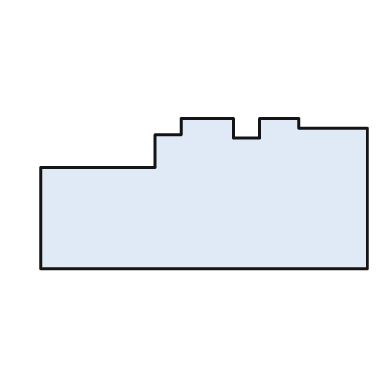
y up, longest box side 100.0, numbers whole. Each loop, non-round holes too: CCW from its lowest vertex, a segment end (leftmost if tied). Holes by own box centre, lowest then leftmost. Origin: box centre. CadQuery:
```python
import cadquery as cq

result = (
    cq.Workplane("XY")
    .moveTo(-50.0, -23.0)
    .lineTo(50.0, -23.0)
    .lineTo(50.0, 20.0)
    .lineTo(29.0, 20.0)
    .lineTo(29.0, 23.0)
    .lineTo(17.0, 23.0)
    .lineTo(17.0, 17.0)
    .lineTo(9.0, 17.0)
    .lineTo(9.0, 23.0)
    .lineTo(-7.0, 23.0)
    .lineTo(-7.0, 18.0)
    .lineTo(-15.0, 18.0)
    .lineTo(-15.0, 8.0)
    .lineTo(-50.0, 8.0)
    .close()
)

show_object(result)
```